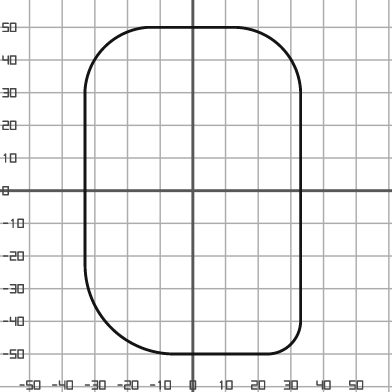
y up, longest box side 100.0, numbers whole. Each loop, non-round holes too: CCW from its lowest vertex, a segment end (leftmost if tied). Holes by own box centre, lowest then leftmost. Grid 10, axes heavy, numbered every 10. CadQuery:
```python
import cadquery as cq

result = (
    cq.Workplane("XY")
    .moveTo(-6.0, -50.0)
    .lineTo(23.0, -50.0)
    .threePointArc((30.0, -47.0), (33.0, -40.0))
    .lineTo(33.0, 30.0)
    .threePointArc((27.0, 44.0), (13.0, 50.0))
    .lineTo(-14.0, 50.0)
    .threePointArc((-27.0, 44.0), (-33.0, 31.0))
    .lineTo(-33.0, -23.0)
    .threePointArc((-25.0, -42.0), (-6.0, -50.0))
    .close()
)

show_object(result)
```